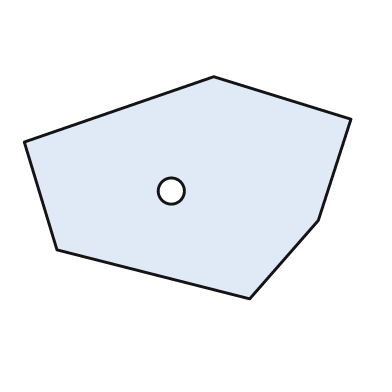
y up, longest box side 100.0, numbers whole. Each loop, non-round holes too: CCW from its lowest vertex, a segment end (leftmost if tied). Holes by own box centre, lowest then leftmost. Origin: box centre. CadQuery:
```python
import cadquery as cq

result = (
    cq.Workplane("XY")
    .moveTo(19.0, -34.0)
    .lineTo(40.0, -10.0)
    .lineTo(50.0, 21.0)
    .lineTo(8.0, 34.0)
    .lineTo(-50.0, 14.0)
    .lineTo(-40.0, -19.0)
    .close()
    .moveTo(-5.0, -1.0)
    .circle(4.0)
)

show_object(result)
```